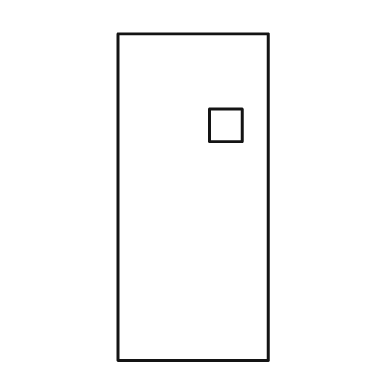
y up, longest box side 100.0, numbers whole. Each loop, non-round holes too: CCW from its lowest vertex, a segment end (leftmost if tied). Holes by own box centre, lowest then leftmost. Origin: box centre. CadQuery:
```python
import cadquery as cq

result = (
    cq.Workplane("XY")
    .moveTo(-23.0, -50.0)
    .lineTo(23.0, -50.0)
    .lineTo(23.0, 50.0)
    .lineTo(-23.0, 50.0)
    .close()
    .moveTo(5.0, 17.0)
    .lineTo(15.0, 17.0)
    .lineTo(15.0, 27.0)
    .lineTo(5.0, 27.0)
    .close()
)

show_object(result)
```